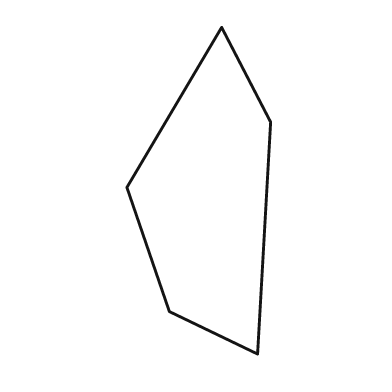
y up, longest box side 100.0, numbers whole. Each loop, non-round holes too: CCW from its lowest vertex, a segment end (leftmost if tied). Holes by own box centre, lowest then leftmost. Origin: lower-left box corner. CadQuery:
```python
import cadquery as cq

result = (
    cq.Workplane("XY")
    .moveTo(40.0, 0.0)
    .lineTo(44.0, 71.0)
    .lineTo(29.0, 100.0)
    .lineTo(0.0, 51.0)
    .lineTo(13.0, 13.0)
    .close()
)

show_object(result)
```